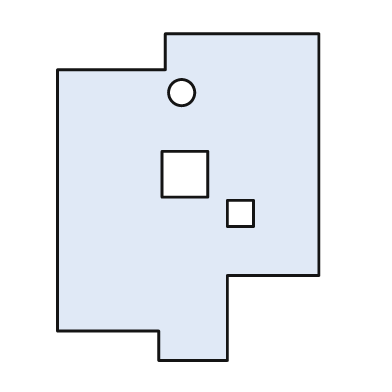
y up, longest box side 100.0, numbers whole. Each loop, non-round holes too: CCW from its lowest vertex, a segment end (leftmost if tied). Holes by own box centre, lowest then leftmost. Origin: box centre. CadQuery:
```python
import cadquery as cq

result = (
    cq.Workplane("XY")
    .moveTo(-9.0, -50.0)
    .lineTo(12.0, -50.0)
    .lineTo(12.0, -24.0)
    .lineTo(40.0, -24.0)
    .lineTo(40.0, 50.0)
    .lineTo(-7.0, 50.0)
    .lineTo(-7.0, 39.0)
    .lineTo(-40.0, 39.0)
    .lineTo(-40.0, -41.0)
    .lineTo(-9.0, -41.0)
    .close()
    .moveTo(12.0, -9.0)
    .lineTo(20.0, -9.0)
    .lineTo(20.0, -1.0)
    .lineTo(12.0, -1.0)
    .close()
    .moveTo(-8.0, 0.0)
    .lineTo(6.0, 0.0)
    .lineTo(6.0, 14.0)
    .lineTo(-8.0, 14.0)
    .close()
    .moveTo(-2.0, 32.0)
    .circle(4.0)
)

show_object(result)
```